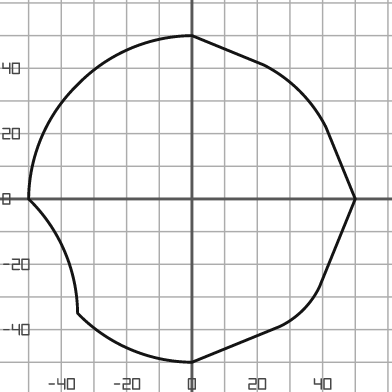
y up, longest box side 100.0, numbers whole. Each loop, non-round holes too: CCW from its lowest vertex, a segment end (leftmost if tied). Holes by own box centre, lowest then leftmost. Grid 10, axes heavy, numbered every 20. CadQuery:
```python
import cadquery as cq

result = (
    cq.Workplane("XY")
    .moveTo(0.0, -50.0)
    .lineTo(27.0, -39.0)
    .threePointArc((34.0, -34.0), (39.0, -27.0))
    .lineTo(50.0, 0.0)
    .lineTo(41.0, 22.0)
    .threePointArc((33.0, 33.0), (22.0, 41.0))
    .lineTo(0.0, 50.0)
    .threePointArc((-19.0, 46.0), (-35.0, 35.0))
    .threePointArc((-46.0, 19.0), (-50.0, 0.0))
    .threePointArc((-39.0, -16.0), (-35.0, -35.0))
    .threePointArc((-19.0, -46.0), (0.0, -50.0))
    .close()
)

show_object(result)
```